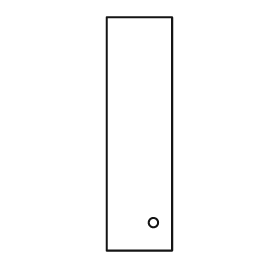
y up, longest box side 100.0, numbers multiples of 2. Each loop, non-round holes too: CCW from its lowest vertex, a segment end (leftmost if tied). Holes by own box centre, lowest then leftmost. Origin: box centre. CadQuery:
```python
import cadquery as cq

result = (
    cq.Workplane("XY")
    .moveTo(-14.0, -50.0)
    .lineTo(14.0, -50.0)
    .lineTo(14.0, 50.0)
    .lineTo(-14.0, 50.0)
    .close()
    .moveTo(6.0, -38.0)
    .circle(2.0)
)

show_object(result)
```